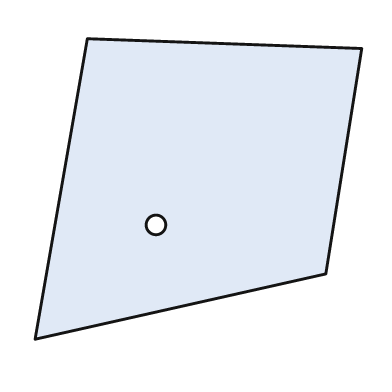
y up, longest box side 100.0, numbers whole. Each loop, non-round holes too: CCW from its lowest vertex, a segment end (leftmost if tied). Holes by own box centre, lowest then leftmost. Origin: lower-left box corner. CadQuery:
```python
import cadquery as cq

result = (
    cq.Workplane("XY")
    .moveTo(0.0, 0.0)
    .lineTo(89.0, 20.0)
    .lineTo(100.0, 89.0)
    .lineTo(16.0, 92.0)
    .close()
    .moveTo(37.0, 35.0)
    .circle(3.0)
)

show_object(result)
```